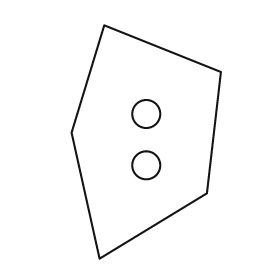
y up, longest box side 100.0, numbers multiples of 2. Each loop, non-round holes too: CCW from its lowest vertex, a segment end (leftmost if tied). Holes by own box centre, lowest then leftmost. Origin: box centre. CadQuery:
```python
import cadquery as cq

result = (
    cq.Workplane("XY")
    .moveTo(-20.0, -50.0)
    .lineTo(26.0, -22.0)
    .lineTo(32.0, 30.0)
    .lineTo(-18.0, 50.0)
    .lineTo(-32.0, 4.0)
    .close()
    .moveTo(0.0, -10.0)
    .circle(6.0)
    .moveTo(0.0, 12.0)
    .circle(6.0)
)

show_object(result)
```